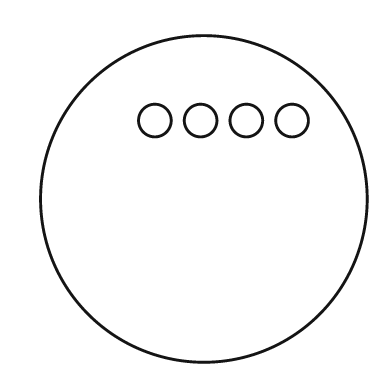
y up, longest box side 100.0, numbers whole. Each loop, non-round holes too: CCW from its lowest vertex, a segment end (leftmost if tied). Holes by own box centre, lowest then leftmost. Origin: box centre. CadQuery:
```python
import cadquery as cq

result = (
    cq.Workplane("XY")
    .moveTo(0.0, 0.0)
    .circle(50.0)
    .moveTo(-15.0, 24.0)
    .circle(5.0)
    .moveTo(-1.0, 24.0)
    .circle(5.0)
    .moveTo(13.0, 24.0)
    .circle(5.0)
    .moveTo(27.0, 24.0)
    .circle(5.0)
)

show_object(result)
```